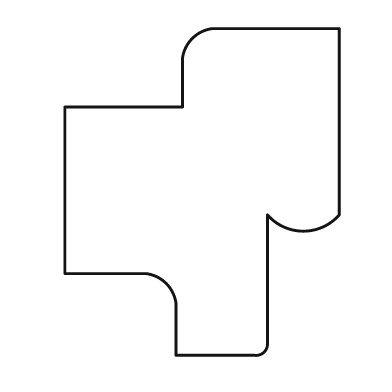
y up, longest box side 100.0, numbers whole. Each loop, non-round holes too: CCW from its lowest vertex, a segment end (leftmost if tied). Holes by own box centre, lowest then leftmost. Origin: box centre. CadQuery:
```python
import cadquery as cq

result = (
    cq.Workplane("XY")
    .moveTo(-8.0, -50.0)
    .lineTo(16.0, -50.0)
    .threePointArc((19.0, -49.0), (20.0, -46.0))
    .lineTo(20.0, -7.0)
    .threePointArc((31.0, -12.0), (42.0, -7.0))
    .lineTo(42.0, 50.0)
    .lineTo(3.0, 50.0)
    .threePointArc((-3.0, 47.0), (-6.0, 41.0))
    .lineTo(-6.0, 26.0)
    .lineTo(-42.0, 26.0)
    .lineTo(-42.0, -25.0)
    .lineTo(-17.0, -25.0)
    .threePointArc((-11.0, -28.0), (-8.0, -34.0))
    .close()
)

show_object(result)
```